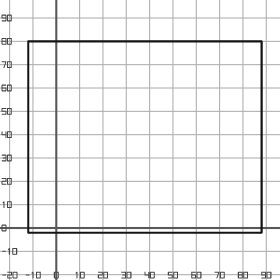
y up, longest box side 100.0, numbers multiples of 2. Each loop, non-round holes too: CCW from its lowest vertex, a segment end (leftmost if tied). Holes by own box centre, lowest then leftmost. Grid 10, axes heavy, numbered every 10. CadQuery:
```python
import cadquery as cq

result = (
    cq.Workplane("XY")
    .moveTo(-12.0, -2.0)
    .lineTo(88.0, -2.0)
    .lineTo(88.0, 80.0)
    .lineTo(-12.0, 80.0)
    .close()
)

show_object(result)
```